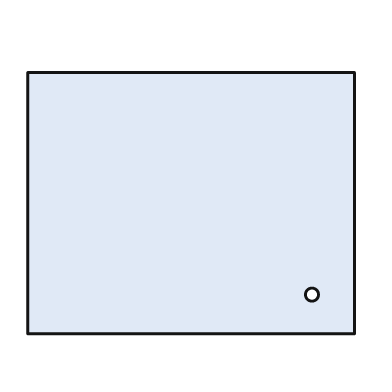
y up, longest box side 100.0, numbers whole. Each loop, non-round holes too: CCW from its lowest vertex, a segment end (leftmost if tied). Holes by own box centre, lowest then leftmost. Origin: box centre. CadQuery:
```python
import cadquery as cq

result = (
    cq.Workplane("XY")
    .moveTo(-50.0, -40.0)
    .lineTo(50.0, -40.0)
    .lineTo(50.0, 40.0)
    .lineTo(-50.0, 40.0)
    .close()
    .moveTo(37.0, -28.0)
    .circle(2.0)
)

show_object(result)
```